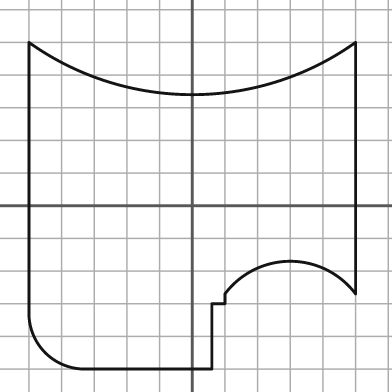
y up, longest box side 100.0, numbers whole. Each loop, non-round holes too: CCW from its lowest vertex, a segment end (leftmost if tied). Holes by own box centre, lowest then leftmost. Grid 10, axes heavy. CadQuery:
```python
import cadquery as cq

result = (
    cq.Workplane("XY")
    .moveTo(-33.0, -50.0)
    .lineTo(6.0, -50.0)
    .lineTo(6.0, -30.0)
    .lineTo(10.0, -30.0)
    .lineTo(10.0, -27.0)
    .threePointArc((30.0, -17.0), (50.0, -27.0))
    .lineTo(50.0, 50.0)
    .threePointArc((0.0, 34.0), (-50.0, 50.0))
    .lineTo(-50.0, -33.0)
    .threePointArc((-45.0, -45.0), (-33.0, -50.0))
    .close()
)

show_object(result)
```